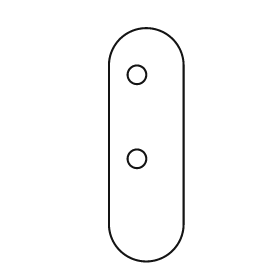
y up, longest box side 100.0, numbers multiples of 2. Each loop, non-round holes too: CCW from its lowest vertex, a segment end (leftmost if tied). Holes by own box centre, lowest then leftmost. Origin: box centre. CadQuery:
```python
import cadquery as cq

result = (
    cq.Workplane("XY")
    .moveTo(-16.0, -34.0)
    .threePointArc((0.0, -50.0), (16.0, -34.0))
    .lineTo(16.0, 34.0)
    .threePointArc((0.0, 50.0), (-16.0, 34.0))
    .close()
    .moveTo(-4.0, -6.0)
    .circle(4.0)
    .moveTo(-4.0, 30.0)
    .circle(4.0)
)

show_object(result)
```